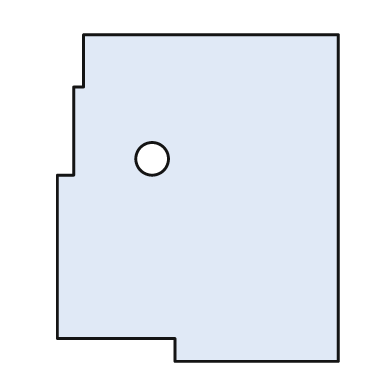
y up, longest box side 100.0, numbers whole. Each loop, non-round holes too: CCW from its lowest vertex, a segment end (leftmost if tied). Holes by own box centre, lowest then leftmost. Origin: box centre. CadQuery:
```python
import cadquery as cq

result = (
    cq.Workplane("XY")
    .moveTo(-7.0, -50.0)
    .lineTo(43.0, -50.0)
    .lineTo(43.0, 50.0)
    .lineTo(-35.0, 50.0)
    .lineTo(-35.0, 34.0)
    .lineTo(-38.0, 34.0)
    .lineTo(-38.0, 7.0)
    .lineTo(-43.0, 7.0)
    .lineTo(-43.0, -43.0)
    .lineTo(-7.0, -43.0)
    .close()
    .moveTo(-14.0, 12.0)
    .circle(5.0)
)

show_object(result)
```